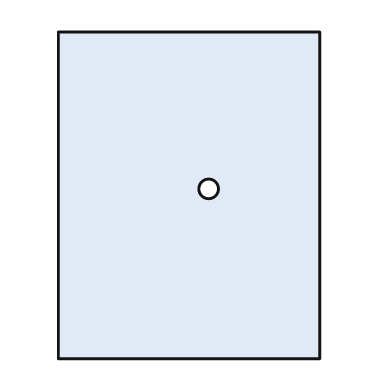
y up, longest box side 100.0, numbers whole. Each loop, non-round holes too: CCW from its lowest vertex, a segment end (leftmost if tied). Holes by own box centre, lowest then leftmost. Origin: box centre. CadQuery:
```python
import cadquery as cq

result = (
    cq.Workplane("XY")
    .moveTo(-40.0, -50.0)
    .lineTo(40.0, -50.0)
    .lineTo(40.0, 50.0)
    .lineTo(-40.0, 50.0)
    .close()
    .moveTo(6.0, 2.0)
    .circle(3.0)
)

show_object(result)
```